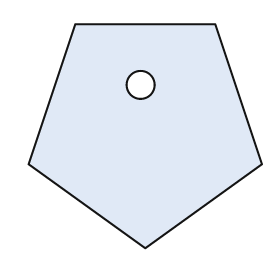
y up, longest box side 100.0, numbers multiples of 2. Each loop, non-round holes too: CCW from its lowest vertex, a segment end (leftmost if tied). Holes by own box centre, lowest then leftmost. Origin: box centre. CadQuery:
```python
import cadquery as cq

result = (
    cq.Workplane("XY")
    .moveTo(0.0, -48.0)
    .lineTo(50.0, -12.0)
    .lineTo(30.0, 48.0)
    .lineTo(-30.0, 48.0)
    .lineTo(-50.0, -12.0)
    .close()
    .moveTo(-2.0, 22.0)
    .circle(6.0)
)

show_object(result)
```